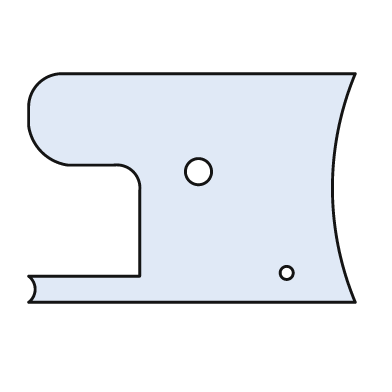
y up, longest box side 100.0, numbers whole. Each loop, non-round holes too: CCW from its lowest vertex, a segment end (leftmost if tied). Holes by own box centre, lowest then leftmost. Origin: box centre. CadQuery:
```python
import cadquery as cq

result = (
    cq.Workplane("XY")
    .moveTo(-50.0, -35.0)
    .lineTo(50.0, -35.0)
    .threePointArc((43.0, 0.0), (50.0, 35.0))
    .lineTo(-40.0, 35.0)
    .threePointArc((-47.0, 32.0), (-50.0, 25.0))
    .lineTo(-50.0, 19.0)
    .threePointArc((-46.0, 11.0), (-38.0, 7.0))
    .lineTo(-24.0, 7.0)
    .threePointArc((-18.0, 5.0), (-16.0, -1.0))
    .lineTo(-16.0, -27.0)
    .lineTo(-50.0, -27.0)
    .threePointArc((-48.0, -31.0), (-50.0, -35.0))
    .close()
    .moveTo(29.0, -26.0)
    .circle(2.0)
    .moveTo(2.0, 5.0)
    .circle(4.0)
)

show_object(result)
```